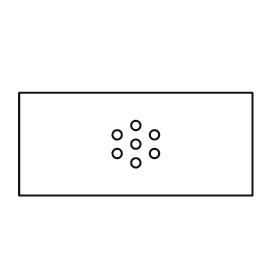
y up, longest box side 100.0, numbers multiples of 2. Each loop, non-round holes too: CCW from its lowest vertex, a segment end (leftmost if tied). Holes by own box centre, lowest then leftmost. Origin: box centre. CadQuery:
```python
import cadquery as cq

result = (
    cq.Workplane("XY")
    .moveTo(-50.0, -22.0)
    .lineTo(50.0, -22.0)
    .lineTo(50.0, 22.0)
    .lineTo(-50.0, 22.0)
    .close()
    .moveTo(0.0, -8.0)
    .circle(2.0)
    .moveTo(-8.0, -4.0)
    .circle(2.0)
    .moveTo(8.0, -4.0)
    .circle(2.0)
    .moveTo(0.0, 0.0)
    .circle(2.0)
    .moveTo(-8.0, 4.0)
    .circle(2.0)
    .moveTo(8.0, 4.0)
    .circle(2.0)
    .moveTo(0.0, 8.0)
    .circle(2.0)
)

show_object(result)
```